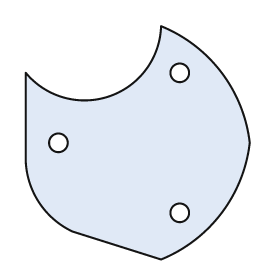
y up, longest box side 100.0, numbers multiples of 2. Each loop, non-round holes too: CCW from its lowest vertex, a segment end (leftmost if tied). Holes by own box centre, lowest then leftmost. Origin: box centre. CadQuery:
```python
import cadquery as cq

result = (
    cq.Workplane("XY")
    .moveTo(10.0, -50.0)
    .threePointArc((36.0, -30.0), (48.0, 0.0))
    .threePointArc((36.0, 30.0), (10.0, 50.0))
    .threePointArc((-12.0, 20.0), (-48.0, 30.0))
    .lineTo(-48.0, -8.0)
    .threePointArc((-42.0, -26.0), (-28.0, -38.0))
    .close()
    .moveTo(18.0, -30.0)
    .circle(4.0)
    .moveTo(-34.0, 0.0)
    .circle(4.0)
    .moveTo(18.0, 30.0)
    .circle(4.0)
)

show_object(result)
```